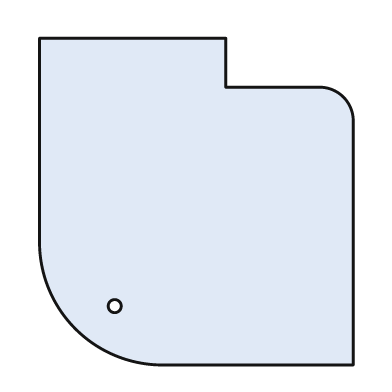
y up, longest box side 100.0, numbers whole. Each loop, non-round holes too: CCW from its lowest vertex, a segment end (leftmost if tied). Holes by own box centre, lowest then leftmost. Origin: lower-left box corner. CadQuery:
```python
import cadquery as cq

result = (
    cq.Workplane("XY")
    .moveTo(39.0, 0.0)
    .lineTo(96.0, 0.0)
    .lineTo(96.0, 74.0)
    .threePointArc((93.0, 82.0), (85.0, 85.0))
    .lineTo(57.0, 85.0)
    .lineTo(57.0, 100.0)
    .lineTo(0.0, 100.0)
    .lineTo(0.0, 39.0)
    .threePointArc((11.0, 11.0), (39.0, 0.0))
    .close()
    .moveTo(23.0, 18.0)
    .circle(2.0)
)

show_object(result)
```